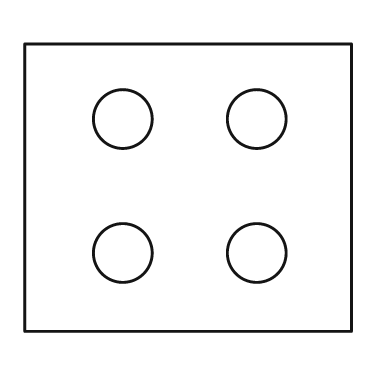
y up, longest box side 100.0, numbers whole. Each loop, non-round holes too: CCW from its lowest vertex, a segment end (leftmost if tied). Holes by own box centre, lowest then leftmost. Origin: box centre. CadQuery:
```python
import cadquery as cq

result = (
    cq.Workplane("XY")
    .moveTo(-50.0, -44.0)
    .lineTo(50.0, -44.0)
    .lineTo(50.0, 44.0)
    .lineTo(-50.0, 44.0)
    .close()
    .moveTo(-20.0, -20.0)
    .circle(9.0)
    .moveTo(21.0, -20.0)
    .circle(9.0)
    .moveTo(-20.0, 21.0)
    .circle(9.0)
    .moveTo(21.0, 21.0)
    .circle(9.0)
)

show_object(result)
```